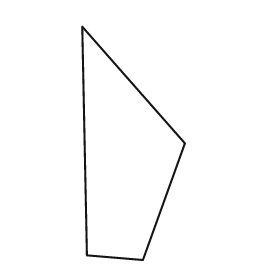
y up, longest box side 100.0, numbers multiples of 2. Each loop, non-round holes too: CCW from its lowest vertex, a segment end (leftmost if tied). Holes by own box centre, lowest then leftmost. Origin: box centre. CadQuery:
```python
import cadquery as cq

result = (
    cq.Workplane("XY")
    .moveTo(4.0, -50.0)
    .lineTo(22.0, 0.0)
    .lineTo(-22.0, 50.0)
    .lineTo(-20.0, -48.0)
    .close()
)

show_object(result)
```